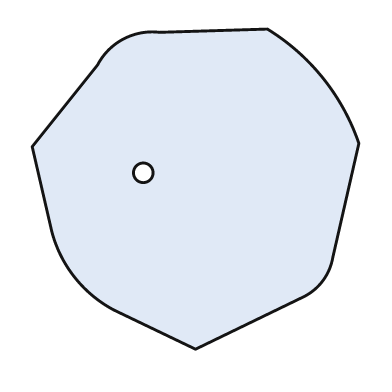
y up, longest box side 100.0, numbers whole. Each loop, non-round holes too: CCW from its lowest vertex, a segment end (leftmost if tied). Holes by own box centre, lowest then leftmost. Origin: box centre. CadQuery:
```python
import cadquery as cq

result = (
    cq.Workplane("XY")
    .moveTo(0.0, -49.0)
    .lineTo(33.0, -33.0)
    .threePointArc((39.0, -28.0), (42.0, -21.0))
    .lineTo(50.0, 14.0)
    .threePointArc((39.0, 34.0), (22.0, 49.0))
    .lineTo(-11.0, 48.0)
    .threePointArc((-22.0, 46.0), (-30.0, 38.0))
    .lineTo(-50.0, 13.0)
    .lineTo(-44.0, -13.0)
    .threePointArc((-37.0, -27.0), (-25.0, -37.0))
    .close()
    .moveTo(-16.0, 5.0)
    .circle(3.0)
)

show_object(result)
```